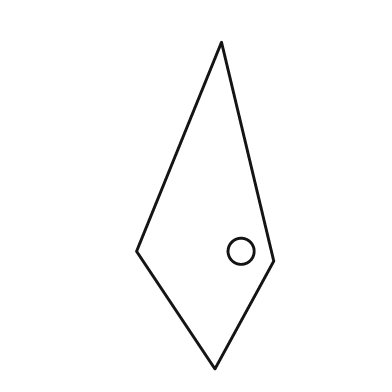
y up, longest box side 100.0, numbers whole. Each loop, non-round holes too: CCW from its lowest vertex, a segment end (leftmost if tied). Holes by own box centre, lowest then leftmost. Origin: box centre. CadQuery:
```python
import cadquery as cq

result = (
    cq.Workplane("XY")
    .moveTo(3.0, -50.0)
    .lineTo(21.0, -17.0)
    .lineTo(5.0, 50.0)
    .lineTo(-21.0, -14.0)
    .close()
    .moveTo(11.0, -14.0)
    .circle(4.0)
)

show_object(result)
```